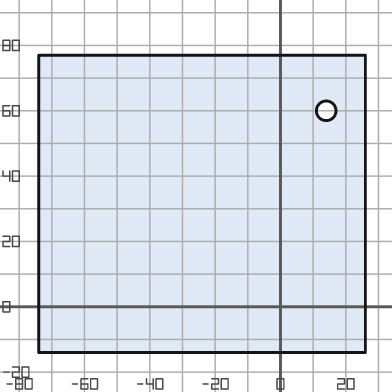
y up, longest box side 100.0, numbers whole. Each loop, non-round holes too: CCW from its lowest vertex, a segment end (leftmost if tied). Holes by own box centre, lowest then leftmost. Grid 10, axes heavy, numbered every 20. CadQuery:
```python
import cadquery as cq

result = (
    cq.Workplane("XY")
    .moveTo(-74.0, -14.0)
    .lineTo(26.0, -14.0)
    .lineTo(26.0, 77.0)
    .lineTo(-74.0, 77.0)
    .close()
    .moveTo(14.0, 60.0)
    .circle(3.0)
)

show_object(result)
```